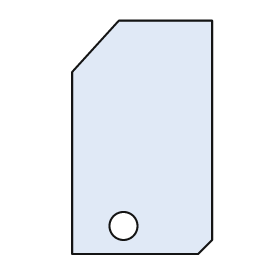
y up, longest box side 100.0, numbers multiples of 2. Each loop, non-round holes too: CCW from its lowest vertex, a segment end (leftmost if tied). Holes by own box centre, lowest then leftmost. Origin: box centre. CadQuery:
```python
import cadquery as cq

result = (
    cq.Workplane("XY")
    .moveTo(-30.0, -50.0)
    .lineTo(24.0, -50.0)
    .lineTo(30.0, -44.0)
    .lineTo(30.0, 50.0)
    .lineTo(-10.0, 50.0)
    .lineTo(-30.0, 28.0)
    .close()
    .moveTo(-8.0, -38.0)
    .circle(6.0)
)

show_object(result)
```